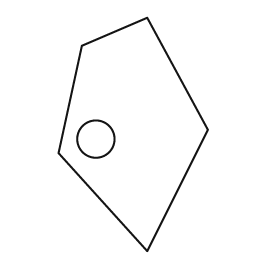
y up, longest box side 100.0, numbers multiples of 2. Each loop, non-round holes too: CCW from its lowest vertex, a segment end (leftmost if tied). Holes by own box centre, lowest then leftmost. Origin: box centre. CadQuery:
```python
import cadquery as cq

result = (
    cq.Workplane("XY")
    .moveTo(6.0, -50.0)
    .lineTo(32.0, 2.0)
    .lineTo(6.0, 50.0)
    .lineTo(-22.0, 38.0)
    .lineTo(-32.0, -8.0)
    .close()
    .moveTo(-16.0, -2.0)
    .circle(8.0)
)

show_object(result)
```